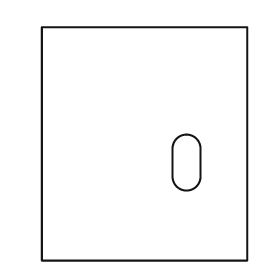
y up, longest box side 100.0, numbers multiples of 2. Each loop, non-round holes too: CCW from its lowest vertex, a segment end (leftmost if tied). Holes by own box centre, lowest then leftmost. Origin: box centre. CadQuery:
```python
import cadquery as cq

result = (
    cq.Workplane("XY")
    .moveTo(-44.0, -50.0)
    .lineTo(44.0, -50.0)
    .lineTo(44.0, 50.0)
    .lineTo(-44.0, 50.0)
    .close()
    .moveTo(12.0, -14.0)
    .threePointArc((18.0, -20.0), (24.0, -14.0))
    .lineTo(24.0, -2.0)
    .threePointArc((18.0, 4.0), (12.0, -2.0))
    .close()
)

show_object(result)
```